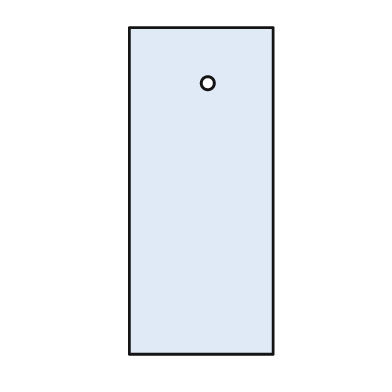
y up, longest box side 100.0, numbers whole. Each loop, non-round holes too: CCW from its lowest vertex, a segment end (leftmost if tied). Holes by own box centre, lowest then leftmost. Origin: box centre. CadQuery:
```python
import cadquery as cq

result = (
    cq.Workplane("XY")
    .moveTo(-22.0, -50.0)
    .lineTo(22.0, -50.0)
    .lineTo(22.0, 50.0)
    .lineTo(-22.0, 50.0)
    .close()
    .moveTo(2.0, 33.0)
    .circle(2.0)
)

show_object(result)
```